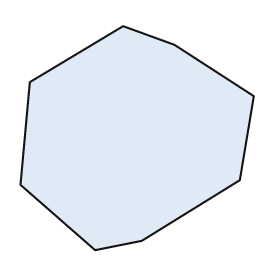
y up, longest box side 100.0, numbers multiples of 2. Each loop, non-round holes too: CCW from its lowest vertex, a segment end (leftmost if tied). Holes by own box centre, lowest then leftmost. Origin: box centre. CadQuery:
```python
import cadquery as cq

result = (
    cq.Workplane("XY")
    .moveTo(-18.0, -48.0)
    .lineTo(2.0, -44.0)
    .lineTo(44.0, -18.0)
    .lineTo(50.0, 18.0)
    .lineTo(16.0, 40.0)
    .lineTo(-6.0, 48.0)
    .lineTo(-46.0, 24.0)
    .lineTo(-50.0, -20.0)
    .close()
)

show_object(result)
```